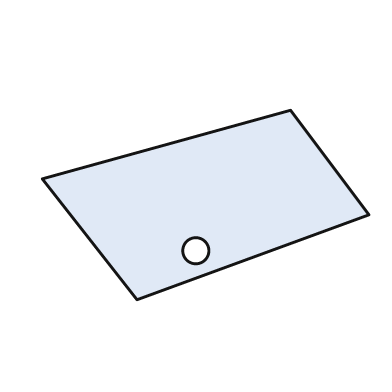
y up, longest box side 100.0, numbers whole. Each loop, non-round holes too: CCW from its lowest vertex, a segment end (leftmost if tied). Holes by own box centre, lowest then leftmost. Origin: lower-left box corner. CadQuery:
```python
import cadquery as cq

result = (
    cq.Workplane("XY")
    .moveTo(29.0, 0.0)
    .lineTo(100.0, 26.0)
    .lineTo(76.0, 58.0)
    .lineTo(0.0, 37.0)
    .close()
    .moveTo(47.0, 15.0)
    .circle(4.0)
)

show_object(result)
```